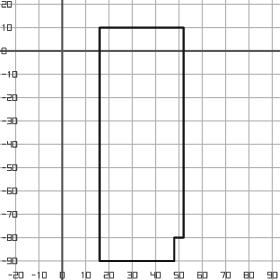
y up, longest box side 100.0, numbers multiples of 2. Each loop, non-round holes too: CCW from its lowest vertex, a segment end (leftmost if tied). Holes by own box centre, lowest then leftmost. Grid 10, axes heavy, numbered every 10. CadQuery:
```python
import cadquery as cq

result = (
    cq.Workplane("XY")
    .moveTo(16.0, -90.0)
    .lineTo(48.0, -90.0)
    .lineTo(48.0, -80.0)
    .lineTo(52.0, -80.0)
    .lineTo(52.0, 10.0)
    .lineTo(16.0, 10.0)
    .close()
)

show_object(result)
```